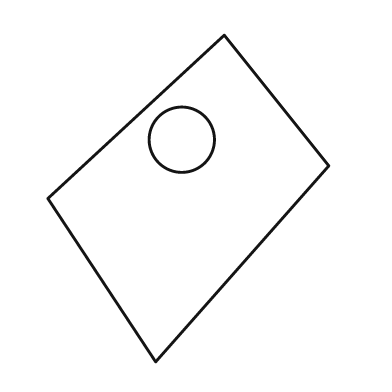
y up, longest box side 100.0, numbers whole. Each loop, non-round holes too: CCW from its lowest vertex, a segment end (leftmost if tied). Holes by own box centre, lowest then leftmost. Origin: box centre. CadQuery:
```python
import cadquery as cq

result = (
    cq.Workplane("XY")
    .moveTo(-10.0, -50.0)
    .lineTo(43.0, 10.0)
    .lineTo(11.0, 50.0)
    .lineTo(-43.0, 0.0)
    .close()
    .moveTo(-2.0, 18.0)
    .circle(10.0)
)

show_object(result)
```